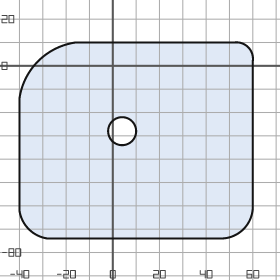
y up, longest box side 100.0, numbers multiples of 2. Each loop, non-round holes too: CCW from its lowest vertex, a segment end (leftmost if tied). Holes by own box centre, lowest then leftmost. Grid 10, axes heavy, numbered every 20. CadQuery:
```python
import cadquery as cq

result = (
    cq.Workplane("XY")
    .moveTo(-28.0, -74.0)
    .lineTo(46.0, -74.0)
    .threePointArc((56.0, -70.0), (60.0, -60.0))
    .lineTo(60.0, 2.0)
    .threePointArc((58.0, 8.0), (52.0, 10.0))
    .lineTo(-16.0, 10.0)
    .threePointArc((-32.0, 2.0), (-40.0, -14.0))
    .lineTo(-40.0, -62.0)
    .threePointArc((-36.0, -70.0), (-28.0, -74.0))
    .close()
    .moveTo(4.0, -28.0)
    .circle(6.0)
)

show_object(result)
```